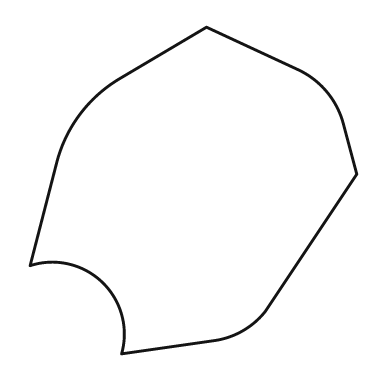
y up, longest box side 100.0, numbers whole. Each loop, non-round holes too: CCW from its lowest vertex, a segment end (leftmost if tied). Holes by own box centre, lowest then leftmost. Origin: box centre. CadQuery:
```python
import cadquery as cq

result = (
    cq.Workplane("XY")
    .moveTo(-22.0, -50.0)
    .lineTo(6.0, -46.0)
    .threePointArc((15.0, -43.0), (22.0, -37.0))
    .lineTo(50.0, 5.0)
    .lineTo(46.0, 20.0)
    .threePointArc((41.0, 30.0), (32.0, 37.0))
    .lineTo(4.0, 50.0)
    .lineTo(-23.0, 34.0)
    .threePointArc((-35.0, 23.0), (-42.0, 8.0))
    .lineTo(-50.0, -23.0)
    .threePointArc((-28.0, -28.0), (-22.0, -50.0))
    .close()
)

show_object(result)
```